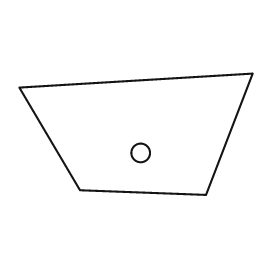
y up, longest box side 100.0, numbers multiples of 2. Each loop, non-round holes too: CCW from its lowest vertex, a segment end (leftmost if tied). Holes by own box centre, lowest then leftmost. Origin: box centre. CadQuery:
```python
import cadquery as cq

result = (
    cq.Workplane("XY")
    .moveTo(30.0, -26.0)
    .lineTo(50.0, 26.0)
    .lineTo(-50.0, 20.0)
    .lineTo(-24.0, -24.0)
    .close()
    .moveTo(2.0, -8.0)
    .circle(4.0)
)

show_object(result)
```